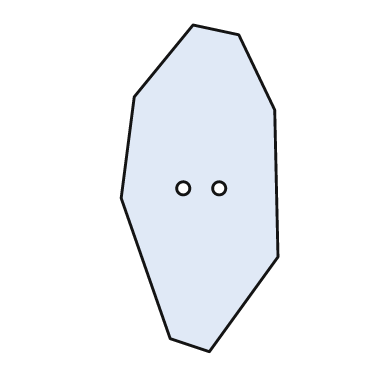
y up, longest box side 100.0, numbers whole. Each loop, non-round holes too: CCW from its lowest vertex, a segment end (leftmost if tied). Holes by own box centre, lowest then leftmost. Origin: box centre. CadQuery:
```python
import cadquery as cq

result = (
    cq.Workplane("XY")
    .moveTo(3.0, -50.0)
    .lineTo(24.0, -21.0)
    .lineTo(23.0, 24.0)
    .lineTo(12.0, 47.0)
    .lineTo(-2.0, 50.0)
    .lineTo(-20.0, 28.0)
    .lineTo(-24.0, -3.0)
    .lineTo(-9.0, -46.0)
    .close()
    .moveTo(-5.0, 0.0)
    .circle(2.0)
    .moveTo(6.0, 0.0)
    .circle(2.0)
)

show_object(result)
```